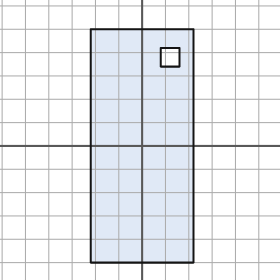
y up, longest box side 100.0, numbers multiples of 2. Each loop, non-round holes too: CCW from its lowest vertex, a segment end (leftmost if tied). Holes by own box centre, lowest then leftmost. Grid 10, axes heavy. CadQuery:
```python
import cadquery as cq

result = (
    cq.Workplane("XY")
    .moveTo(-22.0, -50.0)
    .lineTo(22.0, -50.0)
    .lineTo(22.0, 50.0)
    .lineTo(-22.0, 50.0)
    .close()
    .moveTo(8.0, 34.0)
    .lineTo(16.0, 34.0)
    .lineTo(16.0, 42.0)
    .lineTo(8.0, 42.0)
    .close()
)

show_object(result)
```